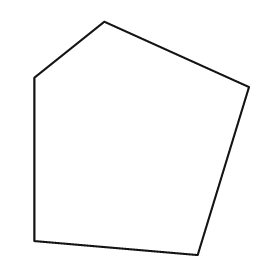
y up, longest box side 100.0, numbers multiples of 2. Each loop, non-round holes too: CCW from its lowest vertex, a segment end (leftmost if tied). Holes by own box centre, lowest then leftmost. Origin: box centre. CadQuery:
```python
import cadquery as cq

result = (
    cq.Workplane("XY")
    .moveTo(24.0, -50.0)
    .lineTo(46.0, 22.0)
    .lineTo(-16.0, 50.0)
    .lineTo(-46.0, 26.0)
    .lineTo(-46.0, -44.0)
    .close()
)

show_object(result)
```